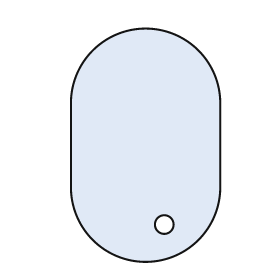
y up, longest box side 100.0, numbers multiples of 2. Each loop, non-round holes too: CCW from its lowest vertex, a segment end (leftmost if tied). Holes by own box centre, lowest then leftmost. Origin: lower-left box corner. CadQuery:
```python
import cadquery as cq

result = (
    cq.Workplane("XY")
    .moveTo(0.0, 32.0)
    .threePointArc((32.0, 0.0), (64.0, 32.0))
    .lineTo(64.0, 68.0)
    .threePointArc((32.0, 100.0), (0.0, 68.0))
    .close()
    .moveTo(40.0, 16.0)
    .circle(4.0)
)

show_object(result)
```